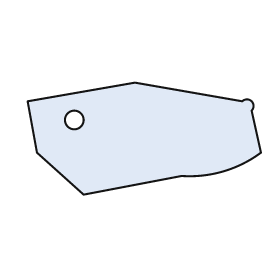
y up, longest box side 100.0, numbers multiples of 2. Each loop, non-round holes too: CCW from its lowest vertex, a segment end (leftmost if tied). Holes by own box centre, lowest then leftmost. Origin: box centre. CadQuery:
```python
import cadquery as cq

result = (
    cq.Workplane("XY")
    .moveTo(-26.0, -24.0)
    .lineTo(16.0, -16.0)
    .threePointArc((34.0, -14.0), (50.0, -6.0))
    .lineTo(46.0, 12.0)
    .threePointArc((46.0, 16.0), (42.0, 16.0))
    .lineTo(-4.0, 24.0)
    .lineTo(-50.0, 16.0)
    .lineTo(-46.0, -6.0)
    .close()
    .moveTo(-30.0, 8.0)
    .circle(4.0)
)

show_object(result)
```